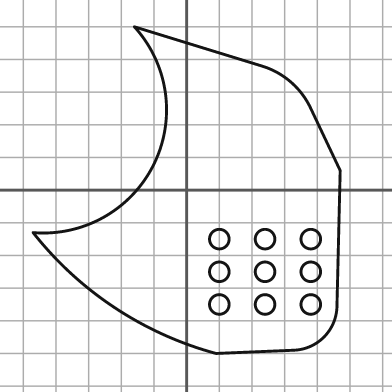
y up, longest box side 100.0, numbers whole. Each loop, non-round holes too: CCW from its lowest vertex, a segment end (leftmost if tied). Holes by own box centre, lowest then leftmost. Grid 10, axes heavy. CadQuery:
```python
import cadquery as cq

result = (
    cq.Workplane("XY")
    .moveTo(9.0, -50.0)
    .lineTo(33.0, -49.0)
    .threePointArc((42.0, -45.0), (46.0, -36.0))
    .lineTo(47.0, 6.0)
    .lineTo(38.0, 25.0)
    .threePointArc((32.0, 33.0), (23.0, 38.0))
    .lineTo(-16.0, 50.0)
    .threePointArc((-10.0, 8.0), (-47.0, -13.0))
    .threePointArc((-22.0, -36.0), (9.0, -50.0))
    .close()
    .moveTo(10.0, -35.0)
    .circle(3.0)
    .moveTo(24.0, -35.0)
    .circle(3.0)
    .moveTo(38.0, -35.0)
    .circle(3.0)
    .moveTo(10.0, -25.0)
    .circle(3.0)
    .moveTo(24.0, -25.0)
    .circle(3.0)
    .moveTo(38.0, -25.0)
    .circle(3.0)
    .moveTo(10.0, -15.0)
    .circle(3.0)
    .moveTo(24.0, -15.0)
    .circle(3.0)
    .moveTo(38.0, -15.0)
    .circle(3.0)
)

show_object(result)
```